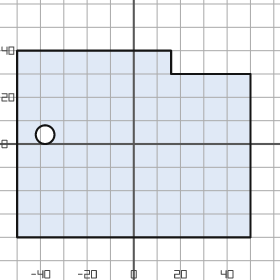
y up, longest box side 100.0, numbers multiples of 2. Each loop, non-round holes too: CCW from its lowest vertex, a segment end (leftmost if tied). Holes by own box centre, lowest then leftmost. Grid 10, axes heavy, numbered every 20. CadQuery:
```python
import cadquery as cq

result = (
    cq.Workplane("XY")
    .moveTo(-50.0, -40.0)
    .lineTo(50.0, -40.0)
    .lineTo(50.0, 30.0)
    .lineTo(16.0, 30.0)
    .lineTo(16.0, 40.0)
    .lineTo(-50.0, 40.0)
    .close()
    .moveTo(-38.0, 4.0)
    .circle(4.0)
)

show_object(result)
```